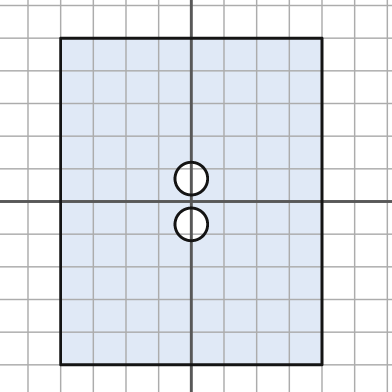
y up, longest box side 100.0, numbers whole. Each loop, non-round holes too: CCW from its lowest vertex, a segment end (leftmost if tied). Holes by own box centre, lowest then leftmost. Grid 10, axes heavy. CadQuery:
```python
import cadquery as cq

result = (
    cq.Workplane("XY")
    .moveTo(-40.0, -50.0)
    .lineTo(40.0, -50.0)
    .lineTo(40.0, 50.0)
    .lineTo(-40.0, 50.0)
    .close()
    .moveTo(0.0, -7.0)
    .circle(5.0)
    .moveTo(0.0, 7.0)
    .circle(5.0)
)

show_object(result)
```